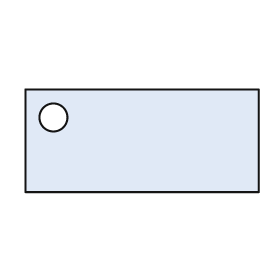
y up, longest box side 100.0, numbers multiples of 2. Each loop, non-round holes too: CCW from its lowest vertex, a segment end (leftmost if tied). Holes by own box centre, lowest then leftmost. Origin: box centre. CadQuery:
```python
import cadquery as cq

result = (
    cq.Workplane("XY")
    .moveTo(-50.0, -22.0)
    .lineTo(50.0, -22.0)
    .lineTo(50.0, 22.0)
    .lineTo(-50.0, 22.0)
    .close()
    .moveTo(-38.0, 10.0)
    .circle(6.0)
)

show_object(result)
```